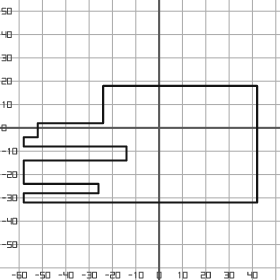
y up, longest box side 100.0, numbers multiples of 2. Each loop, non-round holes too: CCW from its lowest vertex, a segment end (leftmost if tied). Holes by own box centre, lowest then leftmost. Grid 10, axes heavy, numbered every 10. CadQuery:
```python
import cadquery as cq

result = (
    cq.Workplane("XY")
    .moveTo(-58.0, -32.0)
    .lineTo(42.0, -32.0)
    .lineTo(42.0, 18.0)
    .lineTo(-24.0, 18.0)
    .lineTo(-24.0, 2.0)
    .lineTo(-52.0, 2.0)
    .lineTo(-52.0, -4.0)
    .lineTo(-58.0, -4.0)
    .lineTo(-58.0, -8.0)
    .lineTo(-14.0, -8.0)
    .lineTo(-14.0, -14.0)
    .lineTo(-58.0, -14.0)
    .lineTo(-58.0, -24.0)
    .lineTo(-26.0, -24.0)
    .lineTo(-26.0, -28.0)
    .lineTo(-58.0, -28.0)
    .close()
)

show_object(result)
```